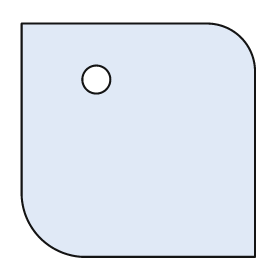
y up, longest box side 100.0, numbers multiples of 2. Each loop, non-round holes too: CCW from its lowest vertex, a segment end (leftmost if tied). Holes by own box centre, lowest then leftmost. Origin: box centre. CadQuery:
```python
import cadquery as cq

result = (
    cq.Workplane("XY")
    .moveTo(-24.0, -50.0)
    .lineTo(50.0, -50.0)
    .lineTo(50.0, 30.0)
    .threePointArc((44.0, 44.0), (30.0, 50.0))
    .lineTo(-50.0, 50.0)
    .lineTo(-50.0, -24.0)
    .threePointArc((-42.0, -42.0), (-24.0, -50.0))
    .close()
    .moveTo(-18.0, 26.0)
    .circle(6.0)
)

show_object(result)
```